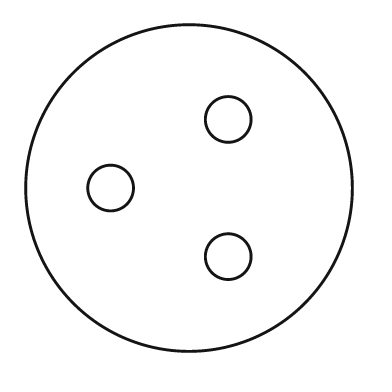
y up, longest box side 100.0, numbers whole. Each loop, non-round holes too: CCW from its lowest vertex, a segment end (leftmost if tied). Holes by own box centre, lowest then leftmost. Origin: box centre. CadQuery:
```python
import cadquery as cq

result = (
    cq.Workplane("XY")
    .moveTo(0.0, 0.0)
    .circle(50.0)
    .moveTo(12.0, -21.0)
    .circle(7.0)
    .moveTo(-24.0, 0.0)
    .circle(7.0)
    .moveTo(12.0, 21.0)
    .circle(7.0)
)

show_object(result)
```